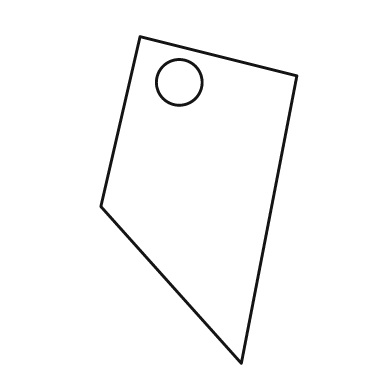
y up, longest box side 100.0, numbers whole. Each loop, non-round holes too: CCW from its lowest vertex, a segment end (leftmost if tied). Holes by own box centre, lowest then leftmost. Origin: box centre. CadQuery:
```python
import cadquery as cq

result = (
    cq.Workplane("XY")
    .moveTo(13.0, -50.0)
    .lineTo(30.0, 38.0)
    .lineTo(-18.0, 50.0)
    .lineTo(-30.0, -2.0)
    .close()
    .moveTo(-6.0, 36.0)
    .circle(7.0)
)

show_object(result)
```